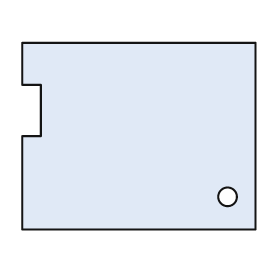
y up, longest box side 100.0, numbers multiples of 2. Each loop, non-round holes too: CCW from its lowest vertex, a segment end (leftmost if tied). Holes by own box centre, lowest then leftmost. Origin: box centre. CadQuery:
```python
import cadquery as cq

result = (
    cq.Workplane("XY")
    .moveTo(-50.0, -40.0)
    .lineTo(50.0, -40.0)
    .lineTo(50.0, 40.0)
    .lineTo(-50.0, 40.0)
    .lineTo(-50.0, 22.0)
    .lineTo(-42.0, 22.0)
    .lineTo(-42.0, 0.0)
    .lineTo(-50.0, 0.0)
    .close()
    .moveTo(38.0, -26.0)
    .circle(4.0)
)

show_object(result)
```